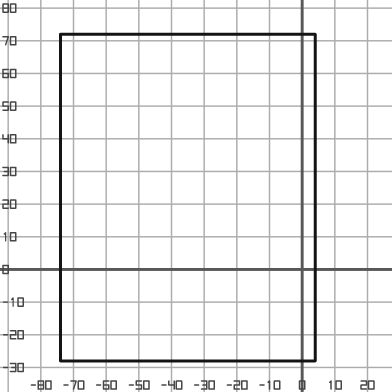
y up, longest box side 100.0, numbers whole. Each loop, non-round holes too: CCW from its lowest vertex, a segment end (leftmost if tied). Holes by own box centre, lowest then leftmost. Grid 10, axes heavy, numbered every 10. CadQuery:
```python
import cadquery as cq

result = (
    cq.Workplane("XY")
    .moveTo(-74.0, -28.0)
    .lineTo(4.0, -28.0)
    .lineTo(4.0, 72.0)
    .lineTo(-74.0, 72.0)
    .close()
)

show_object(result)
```